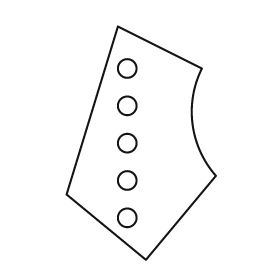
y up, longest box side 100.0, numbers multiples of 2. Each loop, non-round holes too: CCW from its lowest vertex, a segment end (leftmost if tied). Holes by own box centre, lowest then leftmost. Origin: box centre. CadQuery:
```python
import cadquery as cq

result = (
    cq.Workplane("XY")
    .moveTo(2.0, -50.0)
    .lineTo(32.0, -14.0)
    .threePointArc((22.0, 8.0), (26.0, 32.0))
    .lineTo(-10.0, 50.0)
    .lineTo(-32.0, -22.0)
    .close()
    .moveTo(-6.0, -32.0)
    .circle(4.0)
    .moveTo(-6.0, -16.0)
    .circle(4.0)
    .moveTo(-6.0, 0.0)
    .circle(4.0)
    .moveTo(-6.0, 16.0)
    .circle(4.0)
    .moveTo(-6.0, 32.0)
    .circle(4.0)
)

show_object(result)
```